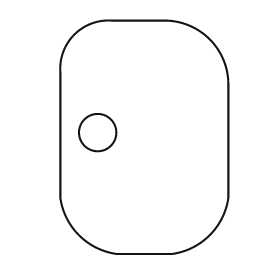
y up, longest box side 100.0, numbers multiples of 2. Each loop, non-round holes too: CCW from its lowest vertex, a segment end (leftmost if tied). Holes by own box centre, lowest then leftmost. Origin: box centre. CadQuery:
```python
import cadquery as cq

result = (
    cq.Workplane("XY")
    .moveTo(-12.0, -50.0)
    .lineTo(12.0, -50.0)
    .threePointArc((28.0, -42.0), (36.0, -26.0))
    .lineTo(36.0, 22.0)
    .threePointArc((28.0, 42.0), (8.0, 50.0))
    .lineTo(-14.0, 50.0)
    .threePointArc((-30.0, 44.0), (-36.0, 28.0))
    .lineTo(-36.0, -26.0)
    .threePointArc((-28.0, -42.0), (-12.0, -50.0))
    .close()
    .moveTo(-20.0, 2.0)
    .circle(8.0)
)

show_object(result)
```